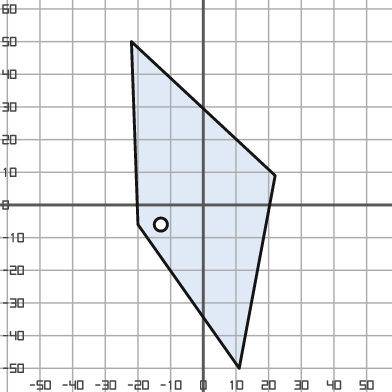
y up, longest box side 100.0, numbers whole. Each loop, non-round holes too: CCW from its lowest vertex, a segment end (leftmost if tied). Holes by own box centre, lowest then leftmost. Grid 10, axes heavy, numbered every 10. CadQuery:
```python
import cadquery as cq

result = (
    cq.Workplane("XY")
    .moveTo(11.0, -50.0)
    .lineTo(22.0, 9.0)
    .lineTo(-22.0, 50.0)
    .lineTo(-20.0, -6.0)
    .close()
    .moveTo(-13.0, -6.0)
    .circle(2.0)
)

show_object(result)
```